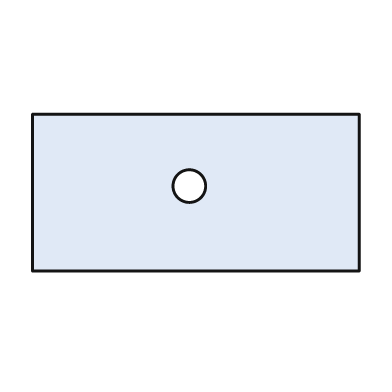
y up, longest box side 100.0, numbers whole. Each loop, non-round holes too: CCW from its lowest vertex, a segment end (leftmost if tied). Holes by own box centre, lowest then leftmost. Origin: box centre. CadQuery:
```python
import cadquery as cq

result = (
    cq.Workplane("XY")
    .moveTo(-50.0, -24.0)
    .lineTo(50.0, -24.0)
    .lineTo(50.0, 24.0)
    .lineTo(-50.0, 24.0)
    .close()
    .moveTo(-2.0, 2.0)
    .circle(5.0)
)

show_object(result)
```